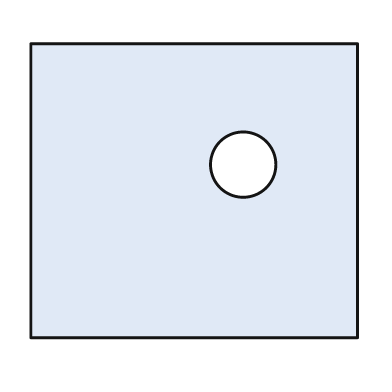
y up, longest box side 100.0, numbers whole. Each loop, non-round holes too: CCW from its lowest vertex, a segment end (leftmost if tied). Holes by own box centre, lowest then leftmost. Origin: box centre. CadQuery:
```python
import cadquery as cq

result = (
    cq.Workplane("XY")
    .moveTo(-50.0, -45.0)
    .lineTo(50.0, -45.0)
    .lineTo(50.0, 45.0)
    .lineTo(-50.0, 45.0)
    .close()
    .moveTo(15.0, 8.0)
    .circle(10.0)
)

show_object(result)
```